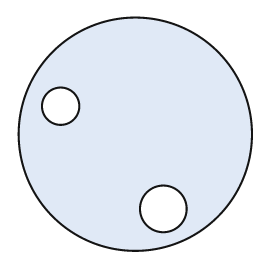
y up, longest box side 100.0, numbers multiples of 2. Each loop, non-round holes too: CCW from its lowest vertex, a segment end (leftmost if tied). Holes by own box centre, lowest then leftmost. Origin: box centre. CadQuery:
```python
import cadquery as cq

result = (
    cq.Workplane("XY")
    .moveTo(0.0, 0.0)
    .circle(50.0)
    .moveTo(12.0, -32.0)
    .circle(10.0)
    .moveTo(-32.0, 12.0)
    .circle(8.0)
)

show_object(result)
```